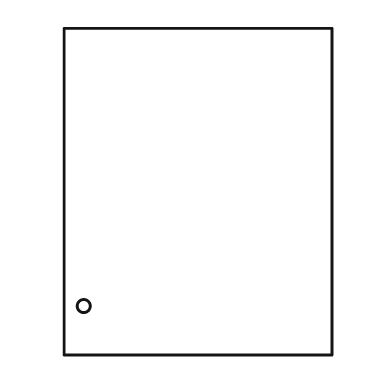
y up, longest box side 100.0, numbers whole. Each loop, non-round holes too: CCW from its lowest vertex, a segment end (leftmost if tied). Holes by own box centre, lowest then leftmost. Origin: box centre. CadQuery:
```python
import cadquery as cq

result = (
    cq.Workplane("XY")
    .moveTo(-41.0, -50.0)
    .lineTo(41.0, -50.0)
    .lineTo(41.0, 50.0)
    .lineTo(-41.0, 50.0)
    .close()
    .moveTo(-35.0, -35.0)
    .circle(2.0)
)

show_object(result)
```